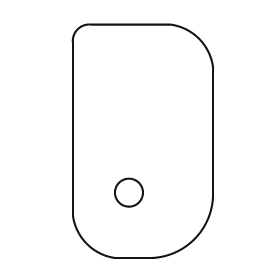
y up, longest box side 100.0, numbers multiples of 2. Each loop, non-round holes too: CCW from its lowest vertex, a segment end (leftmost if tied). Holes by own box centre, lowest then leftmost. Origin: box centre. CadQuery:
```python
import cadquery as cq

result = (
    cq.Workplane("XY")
    .moveTo(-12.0, -50.0)
    .lineTo(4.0, -50.0)
    .threePointArc((22.0, -42.0), (30.0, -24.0))
    .lineTo(30.0, 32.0)
    .threePointArc((24.0, 44.0), (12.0, 50.0))
    .lineTo(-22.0, 50.0)
    .threePointArc((-28.0, 48.0), (-30.0, 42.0))
    .lineTo(-30.0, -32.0)
    .threePointArc((-24.0, -44.0), (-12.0, -50.0))
    .close()
    .moveTo(-6.0, -22.0)
    .circle(6.0)
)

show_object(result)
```